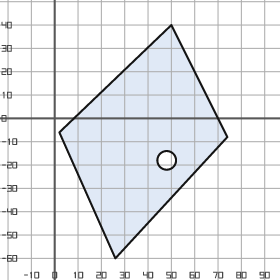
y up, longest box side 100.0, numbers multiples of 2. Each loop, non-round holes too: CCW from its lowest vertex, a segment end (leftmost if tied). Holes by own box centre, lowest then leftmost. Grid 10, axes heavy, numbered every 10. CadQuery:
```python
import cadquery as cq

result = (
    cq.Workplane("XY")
    .moveTo(26.0, -60.0)
    .lineTo(74.0, -8.0)
    .lineTo(50.0, 40.0)
    .lineTo(2.0, -6.0)
    .close()
    .moveTo(48.0, -18.0)
    .circle(4.0)
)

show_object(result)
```